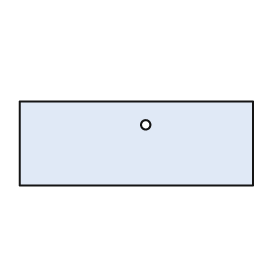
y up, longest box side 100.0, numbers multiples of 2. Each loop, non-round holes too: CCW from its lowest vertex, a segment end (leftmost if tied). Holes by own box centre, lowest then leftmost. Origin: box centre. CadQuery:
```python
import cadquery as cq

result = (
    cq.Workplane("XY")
    .moveTo(-50.0, -18.0)
    .lineTo(50.0, -18.0)
    .lineTo(50.0, 18.0)
    .lineTo(-50.0, 18.0)
    .close()
    .moveTo(4.0, 8.0)
    .circle(2.0)
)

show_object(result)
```